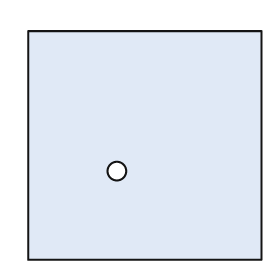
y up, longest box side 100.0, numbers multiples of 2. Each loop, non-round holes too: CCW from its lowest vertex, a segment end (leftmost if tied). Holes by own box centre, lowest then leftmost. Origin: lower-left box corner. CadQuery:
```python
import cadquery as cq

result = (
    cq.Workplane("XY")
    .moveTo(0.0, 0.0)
    .lineTo(100.0, 0.0)
    .lineTo(100.0, 98.0)
    .lineTo(0.0, 98.0)
    .close()
    .moveTo(38.0, 38.0)
    .circle(4.0)
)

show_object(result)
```